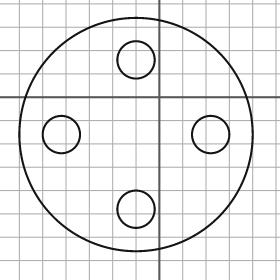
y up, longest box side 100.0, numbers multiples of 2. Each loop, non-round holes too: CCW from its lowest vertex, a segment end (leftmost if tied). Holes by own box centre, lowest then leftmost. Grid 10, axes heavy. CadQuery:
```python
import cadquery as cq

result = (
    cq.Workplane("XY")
    .moveTo(-10.0, -16.0)
    .circle(50.0)
    .moveTo(-10.0, -48.0)
    .circle(8.0)
    .moveTo(-42.0, -16.0)
    .circle(8.0)
    .moveTo(22.0, -16.0)
    .circle(8.0)
    .moveTo(-10.0, 16.0)
    .circle(8.0)
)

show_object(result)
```